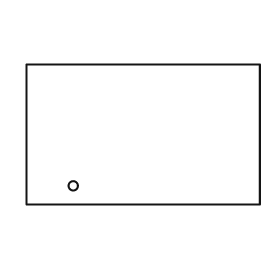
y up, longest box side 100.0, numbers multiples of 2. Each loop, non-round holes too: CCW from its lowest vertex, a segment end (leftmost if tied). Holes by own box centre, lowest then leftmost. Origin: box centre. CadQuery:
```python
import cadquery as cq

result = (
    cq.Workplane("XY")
    .moveTo(-50.0, -30.0)
    .lineTo(50.0, -30.0)
    .lineTo(50.0, 30.0)
    .lineTo(-50.0, 30.0)
    .close()
    .moveTo(-30.0, -22.0)
    .circle(2.0)
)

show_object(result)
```